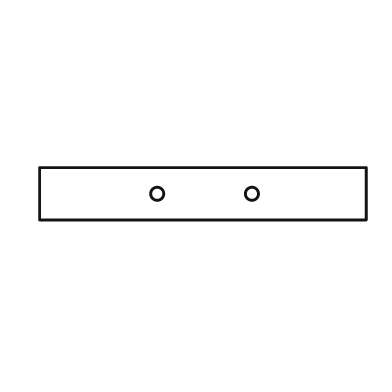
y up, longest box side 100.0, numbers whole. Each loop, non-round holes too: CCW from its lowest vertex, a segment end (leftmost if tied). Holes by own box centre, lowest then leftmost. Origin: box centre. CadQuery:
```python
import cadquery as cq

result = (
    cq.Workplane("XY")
    .moveTo(-50.0, -8.0)
    .lineTo(50.0, -8.0)
    .lineTo(50.0, 8.0)
    .lineTo(-50.0, 8.0)
    .close()
    .moveTo(-14.0, 0.0)
    .circle(2.0)
    .moveTo(15.0, 0.0)
    .circle(2.0)
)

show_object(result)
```